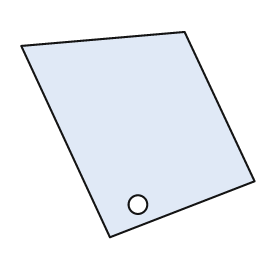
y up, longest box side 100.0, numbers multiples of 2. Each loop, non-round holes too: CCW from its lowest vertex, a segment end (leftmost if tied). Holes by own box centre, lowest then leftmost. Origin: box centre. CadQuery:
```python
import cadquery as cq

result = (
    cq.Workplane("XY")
    .moveTo(-12.0, -44.0)
    .lineTo(50.0, -20.0)
    .lineTo(20.0, 44.0)
    .lineTo(-50.0, 38.0)
    .close()
    .moveTo(0.0, -30.0)
    .circle(4.0)
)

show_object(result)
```